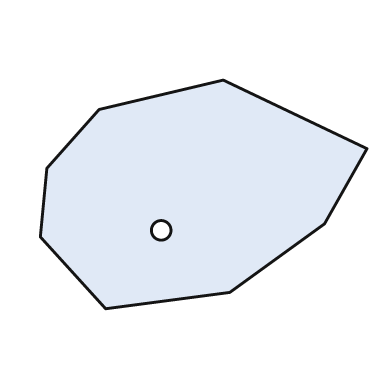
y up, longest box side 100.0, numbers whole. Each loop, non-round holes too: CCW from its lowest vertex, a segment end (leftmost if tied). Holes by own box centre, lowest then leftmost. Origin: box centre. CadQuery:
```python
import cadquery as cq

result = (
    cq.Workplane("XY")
    .moveTo(-30.0, -35.0)
    .lineTo(8.0, -30.0)
    .lineTo(37.0, -9.0)
    .lineTo(50.0, 14.0)
    .lineTo(6.0, 35.0)
    .lineTo(-32.0, 26.0)
    .lineTo(-48.0, 8.0)
    .lineTo(-50.0, -13.0)
    .close()
    .moveTo(-13.0, -11.0)
    .circle(3.0)
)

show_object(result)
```